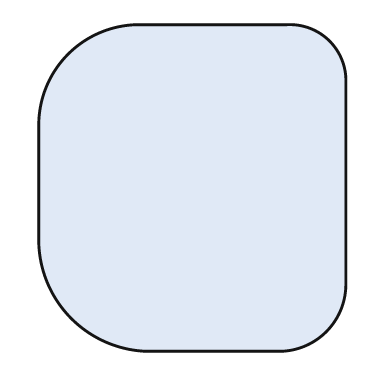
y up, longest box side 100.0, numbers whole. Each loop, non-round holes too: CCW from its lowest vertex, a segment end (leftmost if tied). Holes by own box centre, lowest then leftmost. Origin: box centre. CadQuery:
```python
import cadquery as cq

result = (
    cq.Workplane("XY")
    .moveTo(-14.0, -50.0)
    .lineTo(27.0, -50.0)
    .threePointArc((41.0, -44.0), (47.0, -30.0))
    .lineTo(47.0, 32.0)
    .threePointArc((42.0, 45.0), (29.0, 50.0))
    .lineTo(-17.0, 50.0)
    .threePointArc((-38.0, 41.0), (-47.0, 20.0))
    .lineTo(-47.0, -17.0)
    .threePointArc((-37.0, -40.0), (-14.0, -50.0))
    .close()
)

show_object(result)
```